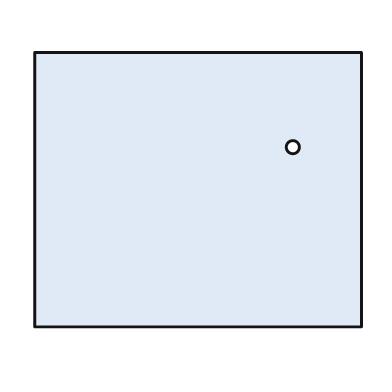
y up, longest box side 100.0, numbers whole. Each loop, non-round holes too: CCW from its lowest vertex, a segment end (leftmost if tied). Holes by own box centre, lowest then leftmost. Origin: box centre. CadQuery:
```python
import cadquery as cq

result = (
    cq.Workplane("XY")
    .moveTo(-50.0, -42.0)
    .lineTo(50.0, -42.0)
    .lineTo(50.0, 42.0)
    .lineTo(-50.0, 42.0)
    .close()
    .moveTo(29.0, 13.0)
    .circle(2.0)
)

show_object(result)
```